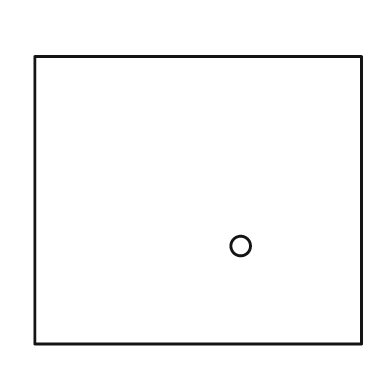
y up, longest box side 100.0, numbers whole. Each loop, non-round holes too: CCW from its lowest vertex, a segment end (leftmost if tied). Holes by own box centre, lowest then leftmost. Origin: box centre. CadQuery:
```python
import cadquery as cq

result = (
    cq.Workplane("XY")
    .moveTo(-50.0, -44.0)
    .lineTo(50.0, -44.0)
    .lineTo(50.0, 44.0)
    .lineTo(-50.0, 44.0)
    .close()
    .moveTo(13.0, -14.0)
    .circle(3.0)
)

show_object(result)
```